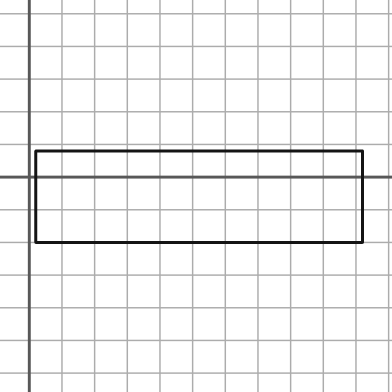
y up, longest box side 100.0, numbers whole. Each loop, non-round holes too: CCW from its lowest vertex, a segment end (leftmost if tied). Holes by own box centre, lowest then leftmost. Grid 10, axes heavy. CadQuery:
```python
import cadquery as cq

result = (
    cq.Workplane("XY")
    .moveTo(2.0, -20.0)
    .lineTo(102.0, -20.0)
    .lineTo(102.0, 8.0)
    .lineTo(2.0, 8.0)
    .close()
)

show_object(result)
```